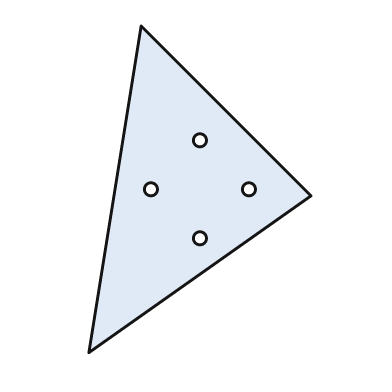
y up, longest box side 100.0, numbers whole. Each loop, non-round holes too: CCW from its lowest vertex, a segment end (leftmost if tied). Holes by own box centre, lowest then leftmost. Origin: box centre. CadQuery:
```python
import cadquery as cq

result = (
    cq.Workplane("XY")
    .moveTo(-34.0, -50.0)
    .lineTo(34.0, -2.0)
    .lineTo(-18.0, 50.0)
    .close()
    .moveTo(0.0, -15.0)
    .circle(2.0)
    .moveTo(-15.0, 0.0)
    .circle(2.0)
    .moveTo(15.0, 0.0)
    .circle(2.0)
    .moveTo(0.0, 15.0)
    .circle(2.0)
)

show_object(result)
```